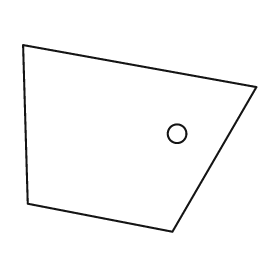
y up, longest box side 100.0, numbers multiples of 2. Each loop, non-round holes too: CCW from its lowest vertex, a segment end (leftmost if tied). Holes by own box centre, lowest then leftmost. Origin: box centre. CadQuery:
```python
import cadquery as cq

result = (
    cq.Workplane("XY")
    .moveTo(14.0, -40.0)
    .lineTo(50.0, 22.0)
    .lineTo(-50.0, 40.0)
    .lineTo(-48.0, -28.0)
    .close()
    .moveTo(16.0, 2.0)
    .circle(4.0)
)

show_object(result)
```